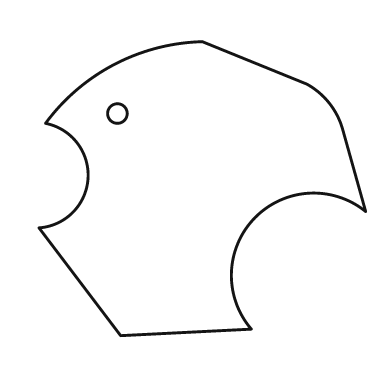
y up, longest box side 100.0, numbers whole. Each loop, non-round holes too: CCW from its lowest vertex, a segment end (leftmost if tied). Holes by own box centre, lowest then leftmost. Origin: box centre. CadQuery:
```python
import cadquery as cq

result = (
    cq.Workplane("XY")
    .moveTo(-25.0, -45.0)
    .lineTo(15.0, -43.0)
    .threePointArc((16.0, -9.0), (50.0, -7.0))
    .lineTo(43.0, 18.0)
    .threePointArc((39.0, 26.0), (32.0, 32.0))
    .lineTo(0.0, 45.0)
    .threePointArc((-27.0, 38.0), (-48.0, 20.0))
    .threePointArc((-35.0, 3.0), (-50.0, -12.0))
    .close()
    .moveTo(-26.0, 23.0)
    .circle(3.0)
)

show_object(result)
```